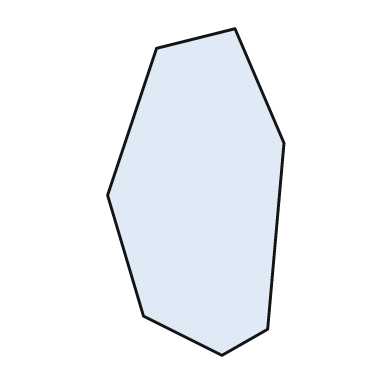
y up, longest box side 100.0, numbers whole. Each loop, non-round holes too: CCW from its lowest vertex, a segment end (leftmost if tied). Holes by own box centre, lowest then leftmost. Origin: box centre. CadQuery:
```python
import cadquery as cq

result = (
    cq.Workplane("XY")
    .moveTo(8.0, -50.0)
    .lineTo(22.0, -42.0)
    .lineTo(27.0, 15.0)
    .lineTo(12.0, 50.0)
    .lineTo(-12.0, 44.0)
    .lineTo(-27.0, -1.0)
    .lineTo(-16.0, -38.0)
    .close()
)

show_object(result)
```